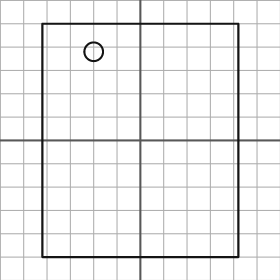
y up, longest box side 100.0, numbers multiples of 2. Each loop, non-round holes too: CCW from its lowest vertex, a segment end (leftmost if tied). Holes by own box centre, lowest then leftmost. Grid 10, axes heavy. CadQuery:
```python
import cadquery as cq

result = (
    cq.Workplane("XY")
    .moveTo(-42.0, -50.0)
    .lineTo(42.0, -50.0)
    .lineTo(42.0, 50.0)
    .lineTo(-42.0, 50.0)
    .close()
    .moveTo(-20.0, 38.0)
    .circle(4.0)
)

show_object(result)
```